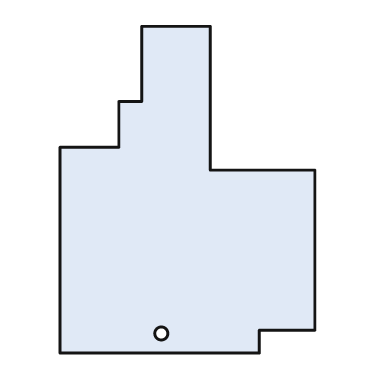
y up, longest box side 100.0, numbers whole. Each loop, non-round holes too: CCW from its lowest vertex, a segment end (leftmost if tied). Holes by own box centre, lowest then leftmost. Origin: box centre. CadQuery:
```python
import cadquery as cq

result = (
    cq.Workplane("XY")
    .moveTo(-39.0, -50.0)
    .lineTo(22.0, -50.0)
    .lineTo(22.0, -43.0)
    .lineTo(39.0, -43.0)
    .lineTo(39.0, 6.0)
    .lineTo(7.0, 6.0)
    .lineTo(7.0, 50.0)
    .lineTo(-14.0, 50.0)
    .lineTo(-14.0, 27.0)
    .lineTo(-21.0, 27.0)
    .lineTo(-21.0, 13.0)
    .lineTo(-39.0, 13.0)
    .close()
    .moveTo(-8.0, -44.0)
    .circle(2.0)
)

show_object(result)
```